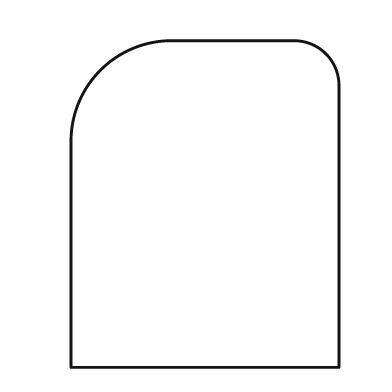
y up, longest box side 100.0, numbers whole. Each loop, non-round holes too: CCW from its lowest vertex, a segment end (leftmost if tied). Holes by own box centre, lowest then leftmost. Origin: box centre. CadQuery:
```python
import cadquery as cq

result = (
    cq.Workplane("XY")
    .moveTo(-41.0, -50.0)
    .lineTo(41.0, -50.0)
    .lineTo(41.0, 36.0)
    .threePointArc((37.0, 46.0), (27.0, 50.0))
    .lineTo(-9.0, 50.0)
    .threePointArc((-32.0, 41.0), (-41.0, 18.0))
    .close()
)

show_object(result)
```